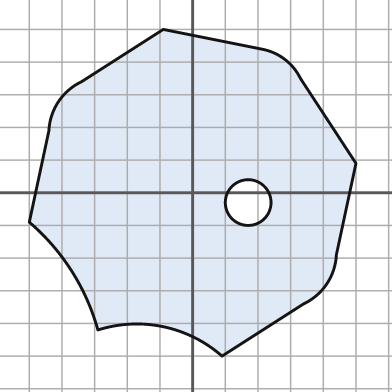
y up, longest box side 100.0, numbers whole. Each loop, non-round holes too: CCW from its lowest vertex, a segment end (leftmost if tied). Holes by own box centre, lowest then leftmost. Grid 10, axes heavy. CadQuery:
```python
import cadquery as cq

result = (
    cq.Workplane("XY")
    .moveTo(9.0, -50.0)
    .lineTo(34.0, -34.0)
    .threePointArc((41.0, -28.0), (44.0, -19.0))
    .lineTo(50.0, 9.0)
    .lineTo(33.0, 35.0)
    .threePointArc((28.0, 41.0), (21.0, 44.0))
    .lineTo(-9.0, 50.0)
    .lineTo(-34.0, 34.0)
    .threePointArc((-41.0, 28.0), (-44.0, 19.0))
    .lineTo(-50.0, -9.0)
    .threePointArc((-37.0, -24.0), (-29.0, -42.0))
    .threePointArc((-9.0, -41.0), (9.0, -50.0))
    .close()
    .moveTo(17.0, -3.0)
    .circle(7.0)
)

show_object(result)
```